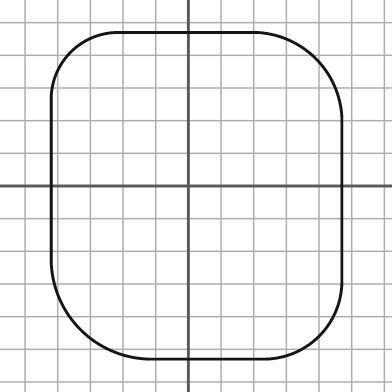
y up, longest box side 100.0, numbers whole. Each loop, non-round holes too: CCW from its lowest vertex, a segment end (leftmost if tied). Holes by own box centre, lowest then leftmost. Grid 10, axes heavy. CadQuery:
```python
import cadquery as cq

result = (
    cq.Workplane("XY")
    .moveTo(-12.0, -53.0)
    .lineTo(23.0, -53.0)
    .threePointArc((40.0, -46.0), (47.0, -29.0))
    .lineTo(47.0, 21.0)
    .threePointArc((39.0, 39.0), (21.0, 47.0))
    .lineTo(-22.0, 47.0)
    .threePointArc((-36.0, 41.0), (-42.0, 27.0))
    .lineTo(-42.0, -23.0)
    .threePointArc((-33.0, -44.0), (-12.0, -53.0))
    .close()
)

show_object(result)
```